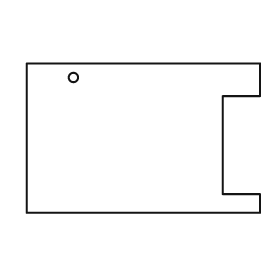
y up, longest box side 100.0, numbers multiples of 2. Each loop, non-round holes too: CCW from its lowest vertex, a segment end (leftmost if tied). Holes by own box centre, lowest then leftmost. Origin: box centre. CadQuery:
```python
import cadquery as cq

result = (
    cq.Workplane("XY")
    .moveTo(-50.0, -32.0)
    .lineTo(50.0, -32.0)
    .lineTo(50.0, -24.0)
    .lineTo(34.0, -24.0)
    .lineTo(34.0, 18.0)
    .lineTo(50.0, 18.0)
    .lineTo(50.0, 32.0)
    .lineTo(-50.0, 32.0)
    .close()
    .moveTo(-30.0, 26.0)
    .circle(2.0)
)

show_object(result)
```